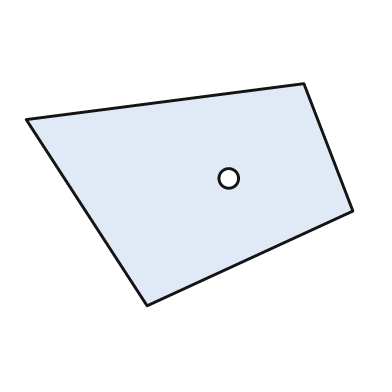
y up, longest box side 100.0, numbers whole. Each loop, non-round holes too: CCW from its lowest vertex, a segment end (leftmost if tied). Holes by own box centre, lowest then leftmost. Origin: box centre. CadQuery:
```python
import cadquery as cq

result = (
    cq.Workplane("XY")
    .moveTo(-13.0, -34.0)
    .lineTo(50.0, -5.0)
    .lineTo(35.0, 34.0)
    .lineTo(-50.0, 23.0)
    .close()
    .moveTo(12.0, 5.0)
    .circle(3.0)
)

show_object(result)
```